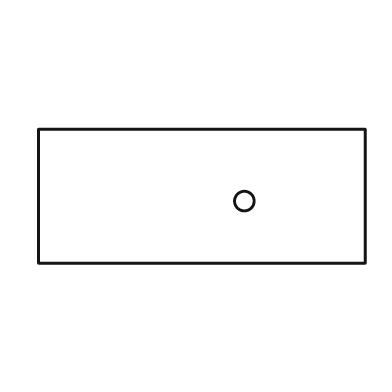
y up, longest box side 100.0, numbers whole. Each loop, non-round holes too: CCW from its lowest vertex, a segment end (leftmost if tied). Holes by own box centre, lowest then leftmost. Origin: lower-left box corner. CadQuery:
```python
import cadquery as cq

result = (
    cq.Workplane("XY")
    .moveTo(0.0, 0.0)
    .lineTo(100.0, 0.0)
    .lineTo(100.0, 41.0)
    .lineTo(0.0, 41.0)
    .close()
    .moveTo(63.0, 19.0)
    .circle(3.0)
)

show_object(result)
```